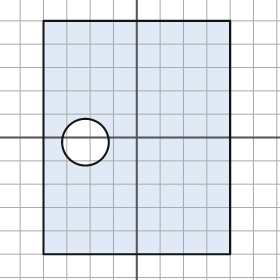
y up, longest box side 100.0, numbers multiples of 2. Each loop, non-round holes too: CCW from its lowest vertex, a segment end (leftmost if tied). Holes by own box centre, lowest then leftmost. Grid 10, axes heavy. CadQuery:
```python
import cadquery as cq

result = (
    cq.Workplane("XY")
    .moveTo(-40.0, -50.0)
    .lineTo(40.0, -50.0)
    .lineTo(40.0, 50.0)
    .lineTo(-40.0, 50.0)
    .close()
    .moveTo(-22.0, -2.0)
    .circle(10.0)
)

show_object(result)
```